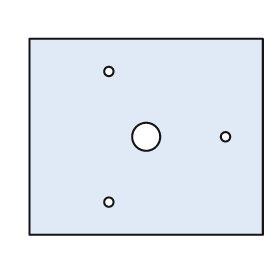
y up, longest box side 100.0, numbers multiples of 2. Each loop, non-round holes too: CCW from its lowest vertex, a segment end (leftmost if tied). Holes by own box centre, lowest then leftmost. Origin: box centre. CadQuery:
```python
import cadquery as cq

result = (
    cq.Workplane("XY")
    .moveTo(-50.0, -42.0)
    .lineTo(50.0, -42.0)
    .lineTo(50.0, 42.0)
    .lineTo(-50.0, 42.0)
    .close()
    .moveTo(-16.0, -28.0)
    .circle(2.0)
    .moveTo(0.0, 0.0)
    .circle(6.0)
    .moveTo(34.0, 0.0)
    .circle(2.0)
    .moveTo(-16.0, 28.0)
    .circle(2.0)
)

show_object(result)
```